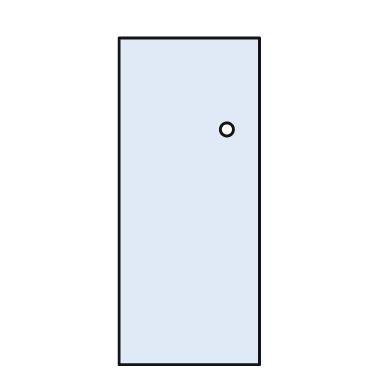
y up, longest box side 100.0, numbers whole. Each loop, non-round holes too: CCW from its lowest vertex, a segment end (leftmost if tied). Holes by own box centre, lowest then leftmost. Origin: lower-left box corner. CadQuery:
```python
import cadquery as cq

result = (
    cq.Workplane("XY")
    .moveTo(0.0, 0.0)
    .lineTo(43.0, 0.0)
    .lineTo(43.0, 100.0)
    .lineTo(0.0, 100.0)
    .close()
    .moveTo(33.0, 72.0)
    .circle(2.0)
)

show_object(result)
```